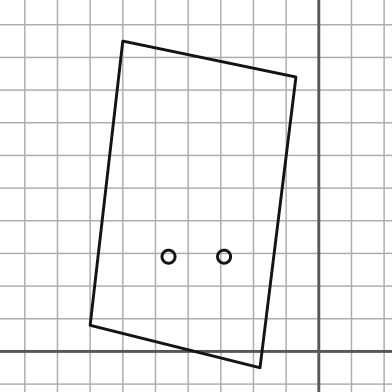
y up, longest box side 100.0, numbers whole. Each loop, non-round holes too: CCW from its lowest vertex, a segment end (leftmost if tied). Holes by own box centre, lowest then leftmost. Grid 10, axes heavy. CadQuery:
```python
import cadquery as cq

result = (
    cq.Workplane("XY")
    .moveTo(-18.0, -5.0)
    .lineTo(-7.0, 84.0)
    .lineTo(-60.0, 95.0)
    .lineTo(-70.0, 8.0)
    .close()
    .moveTo(-46.0, 29.0)
    .circle(2.0)
    .moveTo(-29.0, 29.0)
    .circle(2.0)
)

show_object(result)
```